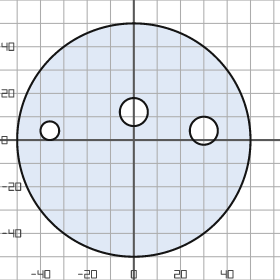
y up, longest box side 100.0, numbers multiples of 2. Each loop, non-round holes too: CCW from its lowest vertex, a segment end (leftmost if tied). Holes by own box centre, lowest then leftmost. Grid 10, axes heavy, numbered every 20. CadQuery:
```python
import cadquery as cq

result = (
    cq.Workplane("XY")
    .moveTo(0.0, 0.0)
    .circle(50.0)
    .moveTo(-36.0, 4.0)
    .circle(4.0)
    .moveTo(30.0, 4.0)
    .circle(6.0)
    .moveTo(0.0, 12.0)
    .circle(6.0)
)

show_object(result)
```